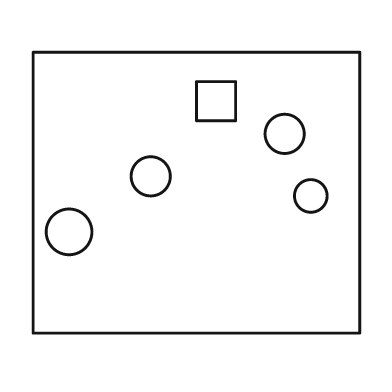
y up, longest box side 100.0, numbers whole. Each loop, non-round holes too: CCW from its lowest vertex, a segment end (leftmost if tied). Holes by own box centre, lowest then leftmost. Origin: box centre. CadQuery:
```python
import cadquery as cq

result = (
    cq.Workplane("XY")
    .moveTo(-50.0, -43.0)
    .lineTo(50.0, -43.0)
    .lineTo(50.0, 43.0)
    .lineTo(-50.0, 43.0)
    .close()
    .moveTo(-39.0, -12.0)
    .circle(7.0)
    .moveTo(35.0, -1.0)
    .circle(5.0)
    .moveTo(-14.0, 5.0)
    .circle(6.0)
    .moveTo(27.0, 18.0)
    .circle(6.0)
    .moveTo(0.0, 22.0)
    .lineTo(12.0, 22.0)
    .lineTo(12.0, 34.0)
    .lineTo(0.0, 34.0)
    .close()
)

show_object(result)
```